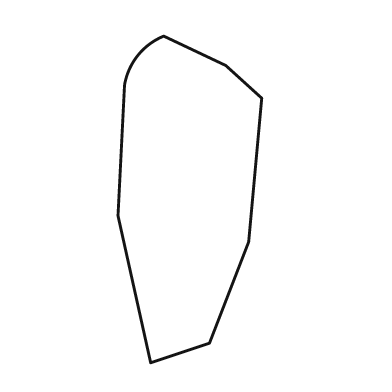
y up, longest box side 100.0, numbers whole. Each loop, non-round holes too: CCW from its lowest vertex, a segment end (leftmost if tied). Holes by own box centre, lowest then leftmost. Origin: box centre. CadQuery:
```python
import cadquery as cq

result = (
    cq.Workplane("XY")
    .moveTo(-12.0, -50.0)
    .lineTo(6.0, -44.0)
    .lineTo(18.0, -13.0)
    .lineTo(22.0, 31.0)
    .lineTo(11.0, 41.0)
    .lineTo(-8.0, 50.0)
    .threePointArc((-16.0, 44.0), (-20.0, 35.0))
    .lineTo(-22.0, -5.0)
    .close()
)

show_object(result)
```